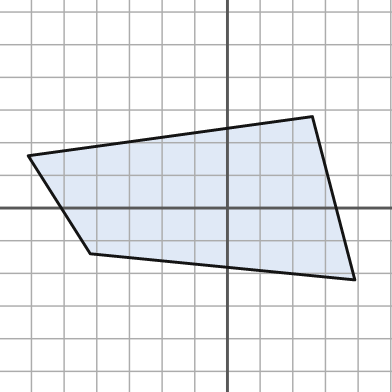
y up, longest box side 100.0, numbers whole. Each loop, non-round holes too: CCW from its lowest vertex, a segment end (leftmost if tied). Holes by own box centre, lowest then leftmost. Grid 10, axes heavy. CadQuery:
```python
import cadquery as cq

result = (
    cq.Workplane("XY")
    .moveTo(39.0, -22.0)
    .lineTo(26.0, 28.0)
    .lineTo(-61.0, 16.0)
    .lineTo(-42.0, -14.0)
    .close()
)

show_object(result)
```